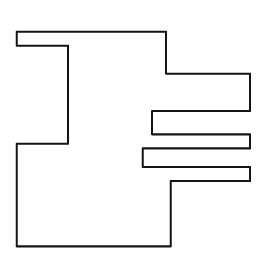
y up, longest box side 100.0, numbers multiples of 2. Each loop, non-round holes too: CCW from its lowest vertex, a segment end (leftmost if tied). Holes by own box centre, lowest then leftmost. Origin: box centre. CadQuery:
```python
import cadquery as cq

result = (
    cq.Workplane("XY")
    .moveTo(-50.0, -46.0)
    .lineTo(16.0, -46.0)
    .lineTo(16.0, -18.0)
    .lineTo(50.0, -18.0)
    .lineTo(50.0, -12.0)
    .lineTo(4.0, -12.0)
    .lineTo(4.0, -4.0)
    .lineTo(50.0, -4.0)
    .lineTo(50.0, 2.0)
    .lineTo(8.0, 2.0)
    .lineTo(8.0, 12.0)
    .lineTo(50.0, 12.0)
    .lineTo(50.0, 28.0)
    .lineTo(14.0, 28.0)
    .lineTo(14.0, 46.0)
    .lineTo(-50.0, 46.0)
    .lineTo(-50.0, 40.0)
    .lineTo(-28.0, 40.0)
    .lineTo(-28.0, -2.0)
    .lineTo(-50.0, -2.0)
    .close()
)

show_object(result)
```